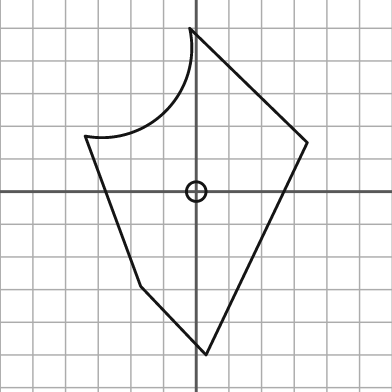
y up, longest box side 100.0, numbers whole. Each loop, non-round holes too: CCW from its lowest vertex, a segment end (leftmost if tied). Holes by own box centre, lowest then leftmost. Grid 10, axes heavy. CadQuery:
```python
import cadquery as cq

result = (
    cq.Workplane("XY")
    .moveTo(3.0, -50.0)
    .lineTo(34.0, 15.0)
    .lineTo(-2.0, 50.0)
    .threePointArc((-9.0, 25.0), (-34.0, 17.0))
    .lineTo(-17.0, -29.0)
    .close()
    .moveTo(0.0, 0.0)
    .circle(3.0)
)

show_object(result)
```